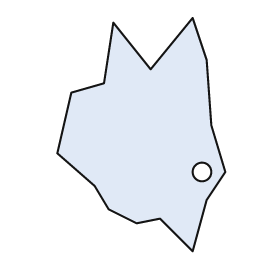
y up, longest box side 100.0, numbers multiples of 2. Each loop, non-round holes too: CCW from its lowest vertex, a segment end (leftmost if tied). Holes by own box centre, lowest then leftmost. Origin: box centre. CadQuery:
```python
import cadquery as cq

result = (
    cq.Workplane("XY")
    .moveTo(22.0, -50.0)
    .lineTo(28.0, -28.0)
    .lineTo(36.0, -16.0)
    .lineTo(30.0, 4.0)
    .lineTo(28.0, 32.0)
    .lineTo(22.0, 50.0)
    .lineTo(4.0, 28.0)
    .lineTo(-12.0, 48.0)
    .lineTo(-16.0, 22.0)
    .lineTo(-30.0, 18.0)
    .lineTo(-36.0, -8.0)
    .lineTo(-20.0, -22.0)
    .lineTo(-14.0, -32.0)
    .lineTo(-2.0, -38.0)
    .lineTo(8.0, -36.0)
    .close()
    .moveTo(26.0, -16.0)
    .circle(4.0)
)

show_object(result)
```